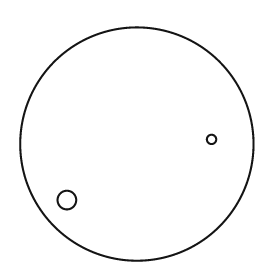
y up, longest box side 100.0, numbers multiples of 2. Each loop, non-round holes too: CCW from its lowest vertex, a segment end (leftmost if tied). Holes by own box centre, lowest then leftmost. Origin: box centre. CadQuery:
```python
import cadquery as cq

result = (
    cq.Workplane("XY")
    .moveTo(0.0, 0.0)
    .circle(50.0)
    .moveTo(-30.0, -24.0)
    .circle(4.0)
    .moveTo(32.0, 2.0)
    .circle(2.0)
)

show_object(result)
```